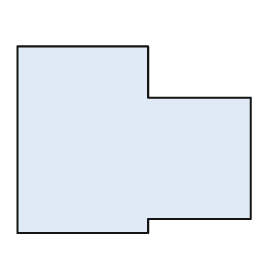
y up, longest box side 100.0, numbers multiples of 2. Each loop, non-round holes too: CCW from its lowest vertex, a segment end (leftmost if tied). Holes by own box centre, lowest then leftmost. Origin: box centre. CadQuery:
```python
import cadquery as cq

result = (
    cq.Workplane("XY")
    .moveTo(-50.0, -40.0)
    .lineTo(6.0, -40.0)
    .lineTo(6.0, -34.0)
    .lineTo(50.0, -34.0)
    .lineTo(50.0, 18.0)
    .lineTo(6.0, 18.0)
    .lineTo(6.0, 40.0)
    .lineTo(-50.0, 40.0)
    .close()
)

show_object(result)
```